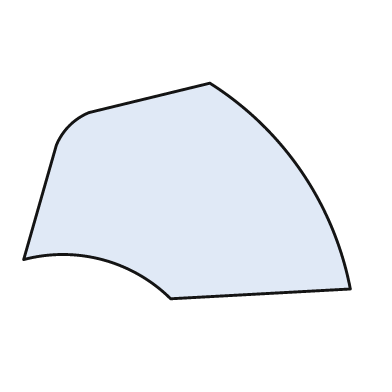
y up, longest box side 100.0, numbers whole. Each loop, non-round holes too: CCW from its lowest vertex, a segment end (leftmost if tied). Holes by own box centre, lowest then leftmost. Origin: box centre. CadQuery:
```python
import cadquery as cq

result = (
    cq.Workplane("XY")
    .moveTo(-5.0, -33.0)
    .lineTo(50.0, -30.0)
    .threePointArc((35.0, 6.0), (7.0, 33.0))
    .lineTo(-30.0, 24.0)
    .threePointArc((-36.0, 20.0), (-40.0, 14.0))
    .lineTo(-50.0, -21.0)
    .threePointArc((-26.0, -21.0), (-5.0, -33.0))
    .close()
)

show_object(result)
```